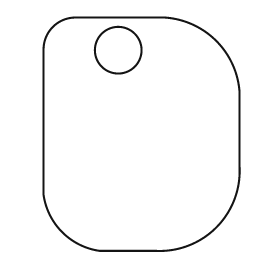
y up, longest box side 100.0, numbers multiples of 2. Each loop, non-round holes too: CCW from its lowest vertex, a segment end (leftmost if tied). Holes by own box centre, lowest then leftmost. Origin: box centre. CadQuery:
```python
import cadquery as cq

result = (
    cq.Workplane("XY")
    .moveTo(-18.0, -50.0)
    .lineTo(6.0, -50.0)
    .threePointArc((32.0, -40.0), (42.0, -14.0))
    .lineTo(42.0, 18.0)
    .threePointArc((32.0, 40.0), (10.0, 50.0))
    .lineTo(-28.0, 50.0)
    .threePointArc((-38.0, 46.0), (-42.0, 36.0))
    .lineTo(-42.0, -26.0)
    .threePointArc((-34.0, -42.0), (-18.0, -50.0))
    .close()
    .moveTo(-10.0, 36.0)
    .circle(10.0)
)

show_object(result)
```